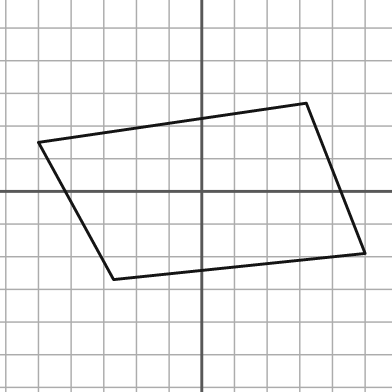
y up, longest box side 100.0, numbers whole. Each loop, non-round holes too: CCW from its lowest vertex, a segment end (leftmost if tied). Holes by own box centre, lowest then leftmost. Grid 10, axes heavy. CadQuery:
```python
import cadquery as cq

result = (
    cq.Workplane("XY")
    .moveTo(-27.0, -27.0)
    .lineTo(50.0, -19.0)
    .lineTo(32.0, 27.0)
    .lineTo(-50.0, 15.0)
    .close()
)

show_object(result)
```